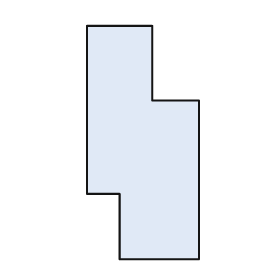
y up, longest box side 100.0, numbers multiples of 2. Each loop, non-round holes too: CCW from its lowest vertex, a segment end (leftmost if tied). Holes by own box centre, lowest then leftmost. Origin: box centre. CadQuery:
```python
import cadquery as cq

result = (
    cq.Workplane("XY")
    .moveTo(-10.0, -50.0)
    .lineTo(24.0, -50.0)
    .lineTo(24.0, 18.0)
    .lineTo(4.0, 18.0)
    .lineTo(4.0, 50.0)
    .lineTo(-24.0, 50.0)
    .lineTo(-24.0, -22.0)
    .lineTo(-10.0, -22.0)
    .close()
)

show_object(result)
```